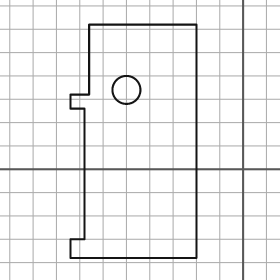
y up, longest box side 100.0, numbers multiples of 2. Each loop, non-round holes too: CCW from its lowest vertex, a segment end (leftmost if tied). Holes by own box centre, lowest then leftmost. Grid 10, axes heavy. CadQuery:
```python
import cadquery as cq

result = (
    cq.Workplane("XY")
    .moveTo(-74.0, -38.0)
    .lineTo(-20.0, -38.0)
    .lineTo(-20.0, 62.0)
    .lineTo(-66.0, 62.0)
    .lineTo(-66.0, 32.0)
    .lineTo(-74.0, 32.0)
    .lineTo(-74.0, 26.0)
    .lineTo(-68.0, 26.0)
    .lineTo(-68.0, -30.0)
    .lineTo(-74.0, -30.0)
    .close()
    .moveTo(-50.0, 34.0)
    .circle(6.0)
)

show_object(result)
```